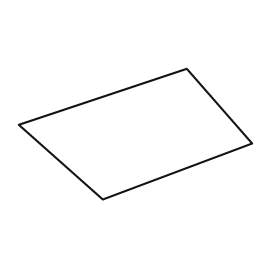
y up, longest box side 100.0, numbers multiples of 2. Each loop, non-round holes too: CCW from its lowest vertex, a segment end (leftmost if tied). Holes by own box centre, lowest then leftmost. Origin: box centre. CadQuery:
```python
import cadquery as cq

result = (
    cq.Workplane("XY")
    .moveTo(-14.0, -28.0)
    .lineTo(50.0, -4.0)
    .lineTo(22.0, 28.0)
    .lineTo(-50.0, 4.0)
    .close()
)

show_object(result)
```